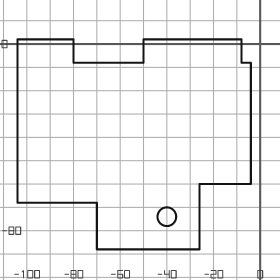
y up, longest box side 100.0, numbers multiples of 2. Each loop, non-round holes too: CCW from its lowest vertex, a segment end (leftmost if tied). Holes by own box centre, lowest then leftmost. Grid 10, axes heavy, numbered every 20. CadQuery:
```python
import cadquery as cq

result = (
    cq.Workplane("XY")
    .moveTo(-70.0, -88.0)
    .lineTo(-26.0, -88.0)
    .lineTo(-26.0, -60.0)
    .lineTo(-4.0, -60.0)
    .lineTo(-4.0, -8.0)
    .lineTo(-8.0, -8.0)
    .lineTo(-8.0, 2.0)
    .lineTo(-50.0, 2.0)
    .lineTo(-50.0, -8.0)
    .lineTo(-80.0, -8.0)
    .lineTo(-80.0, 2.0)
    .lineTo(-104.0, 2.0)
    .lineTo(-104.0, -68.0)
    .lineTo(-70.0, -68.0)
    .close()
    .moveTo(-40.0, -74.0)
    .circle(4.0)
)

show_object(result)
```